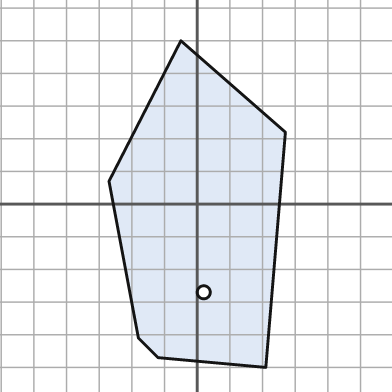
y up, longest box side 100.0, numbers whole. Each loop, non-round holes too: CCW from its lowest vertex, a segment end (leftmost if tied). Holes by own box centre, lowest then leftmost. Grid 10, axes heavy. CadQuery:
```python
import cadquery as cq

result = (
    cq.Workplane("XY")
    .moveTo(21.0, -50.0)
    .lineTo(27.0, 22.0)
    .lineTo(-5.0, 50.0)
    .lineTo(-27.0, 7.0)
    .lineTo(-18.0, -41.0)
    .lineTo(-12.0, -47.0)
    .close()
    .moveTo(2.0, -27.0)
    .circle(2.0)
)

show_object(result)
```